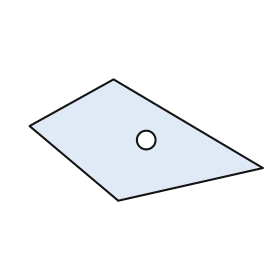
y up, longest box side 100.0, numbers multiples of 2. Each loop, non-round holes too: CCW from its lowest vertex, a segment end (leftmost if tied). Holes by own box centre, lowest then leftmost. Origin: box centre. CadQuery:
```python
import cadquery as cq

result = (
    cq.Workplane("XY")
    .moveTo(-12.0, -26.0)
    .lineTo(50.0, -12.0)
    .lineTo(-14.0, 26.0)
    .lineTo(-50.0, 6.0)
    .close()
    .moveTo(0.0, 0.0)
    .circle(4.0)
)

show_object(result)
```